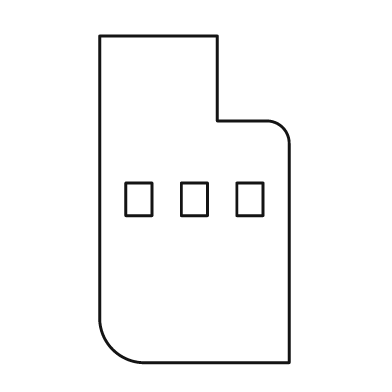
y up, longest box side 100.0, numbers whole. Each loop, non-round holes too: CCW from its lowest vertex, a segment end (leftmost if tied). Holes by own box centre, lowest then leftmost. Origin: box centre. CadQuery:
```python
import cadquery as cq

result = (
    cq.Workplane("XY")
    .moveTo(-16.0, -50.0)
    .lineTo(29.0, -50.0)
    .lineTo(29.0, 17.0)
    .threePointArc((27.0, 22.0), (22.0, 24.0))
    .lineTo(7.0, 24.0)
    .lineTo(7.0, 50.0)
    .lineTo(-29.0, 50.0)
    .lineTo(-29.0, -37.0)
    .threePointArc((-25.0, -46.0), (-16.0, -50.0))
    .close()
    .moveTo(-21.0, -5.0)
    .lineTo(-13.0, -5.0)
    .lineTo(-13.0, 5.0)
    .lineTo(-21.0, 5.0)
    .close()
    .moveTo(-4.0, -5.0)
    .lineTo(4.0, -5.0)
    .lineTo(4.0, 5.0)
    .lineTo(-4.0, 5.0)
    .close()
    .moveTo(13.0, -5.0)
    .lineTo(21.0, -5.0)
    .lineTo(21.0, 5.0)
    .lineTo(13.0, 5.0)
    .close()
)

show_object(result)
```